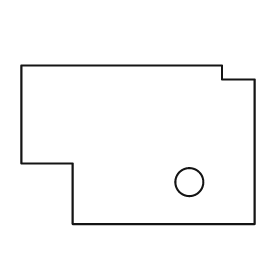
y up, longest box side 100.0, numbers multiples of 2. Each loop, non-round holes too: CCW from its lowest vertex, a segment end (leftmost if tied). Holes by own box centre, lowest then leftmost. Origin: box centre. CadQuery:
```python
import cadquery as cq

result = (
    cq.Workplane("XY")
    .moveTo(-28.0, -34.0)
    .lineTo(50.0, -34.0)
    .lineTo(50.0, 28.0)
    .lineTo(36.0, 28.0)
    .lineTo(36.0, 34.0)
    .lineTo(-50.0, 34.0)
    .lineTo(-50.0, -8.0)
    .lineTo(-28.0, -8.0)
    .close()
    .moveTo(22.0, -16.0)
    .circle(6.0)
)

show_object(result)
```